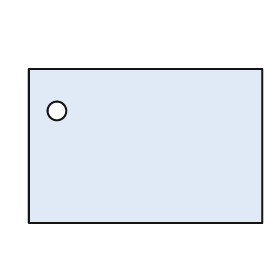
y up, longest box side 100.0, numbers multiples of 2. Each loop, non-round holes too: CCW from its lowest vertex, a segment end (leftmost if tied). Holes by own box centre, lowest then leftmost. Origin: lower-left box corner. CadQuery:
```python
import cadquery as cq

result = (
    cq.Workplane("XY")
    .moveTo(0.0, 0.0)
    .lineTo(100.0, 0.0)
    .lineTo(100.0, 66.0)
    .lineTo(0.0, 66.0)
    .close()
    .moveTo(12.0, 48.0)
    .circle(4.0)
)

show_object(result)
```